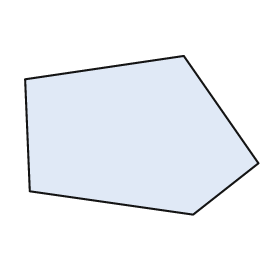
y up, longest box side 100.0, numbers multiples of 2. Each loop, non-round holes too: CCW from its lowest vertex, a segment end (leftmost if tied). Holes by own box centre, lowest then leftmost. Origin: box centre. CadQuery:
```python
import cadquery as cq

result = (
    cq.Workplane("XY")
    .moveTo(22.0, -34.0)
    .lineTo(50.0, -12.0)
    .lineTo(18.0, 34.0)
    .lineTo(-50.0, 24.0)
    .lineTo(-48.0, -24.0)
    .close()
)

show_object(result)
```